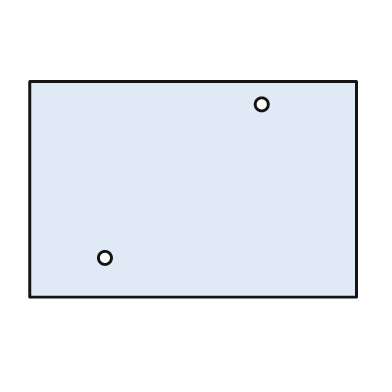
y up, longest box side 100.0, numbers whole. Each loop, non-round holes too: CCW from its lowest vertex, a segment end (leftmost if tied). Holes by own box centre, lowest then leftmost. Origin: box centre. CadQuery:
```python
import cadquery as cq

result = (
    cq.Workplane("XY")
    .moveTo(-50.0, -33.0)
    .lineTo(50.0, -33.0)
    .lineTo(50.0, 33.0)
    .lineTo(-50.0, 33.0)
    .close()
    .moveTo(-27.0, -21.0)
    .circle(2.0)
    .moveTo(21.0, 26.0)
    .circle(2.0)
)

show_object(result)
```